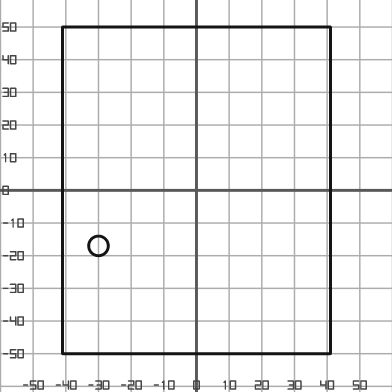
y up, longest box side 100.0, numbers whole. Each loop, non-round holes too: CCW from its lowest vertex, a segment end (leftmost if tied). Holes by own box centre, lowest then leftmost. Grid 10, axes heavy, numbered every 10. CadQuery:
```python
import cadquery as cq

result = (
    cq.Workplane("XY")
    .moveTo(-41.0, -50.0)
    .lineTo(41.0, -50.0)
    .lineTo(41.0, 50.0)
    .lineTo(-41.0, 50.0)
    .close()
    .moveTo(-30.0, -17.0)
    .circle(3.0)
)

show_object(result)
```